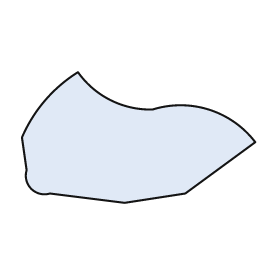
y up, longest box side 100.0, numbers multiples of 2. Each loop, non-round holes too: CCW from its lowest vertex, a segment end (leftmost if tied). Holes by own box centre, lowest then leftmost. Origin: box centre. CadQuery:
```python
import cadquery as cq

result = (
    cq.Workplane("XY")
    .moveTo(-6.0, -28.0)
    .lineTo(20.0, -24.0)
    .lineTo(50.0, -2.0)
    .threePointArc((30.0, 12.0), (6.0, 12.0))
    .threePointArc((-12.0, 16.0), (-26.0, 28.0))
    .threePointArc((-40.0, 16.0), (-50.0, 0.0))
    .lineTo(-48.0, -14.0)
    .threePointArc((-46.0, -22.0), (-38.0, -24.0))
    .close()
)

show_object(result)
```